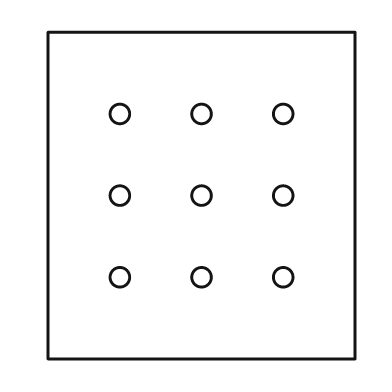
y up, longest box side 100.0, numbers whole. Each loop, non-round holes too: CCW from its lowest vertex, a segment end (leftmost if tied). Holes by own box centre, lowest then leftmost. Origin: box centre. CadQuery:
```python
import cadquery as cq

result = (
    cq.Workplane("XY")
    .moveTo(-47.0, -50.0)
    .lineTo(47.0, -50.0)
    .lineTo(47.0, 50.0)
    .lineTo(-47.0, 50.0)
    .close()
    .moveTo(-25.0, -25.0)
    .circle(3.0)
    .moveTo(0.0, -25.0)
    .circle(3.0)
    .moveTo(25.0, -25.0)
    .circle(3.0)
    .moveTo(-25.0, 0.0)
    .circle(3.0)
    .moveTo(0.0, 0.0)
    .circle(3.0)
    .moveTo(25.0, 0.0)
    .circle(3.0)
    .moveTo(-25.0, 25.0)
    .circle(3.0)
    .moveTo(0.0, 25.0)
    .circle(3.0)
    .moveTo(25.0, 25.0)
    .circle(3.0)
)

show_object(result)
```